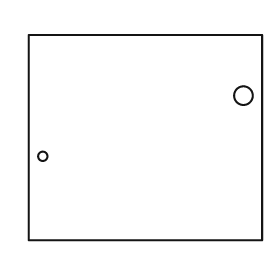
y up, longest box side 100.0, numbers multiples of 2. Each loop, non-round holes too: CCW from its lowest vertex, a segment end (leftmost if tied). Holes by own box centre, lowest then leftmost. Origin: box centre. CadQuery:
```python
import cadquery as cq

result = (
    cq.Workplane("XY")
    .moveTo(-50.0, -44.0)
    .lineTo(50.0, -44.0)
    .lineTo(50.0, 44.0)
    .lineTo(-50.0, 44.0)
    .close()
    .moveTo(-44.0, -8.0)
    .circle(2.0)
    .moveTo(42.0, 18.0)
    .circle(4.0)
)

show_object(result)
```